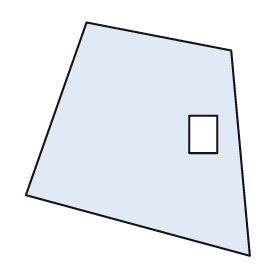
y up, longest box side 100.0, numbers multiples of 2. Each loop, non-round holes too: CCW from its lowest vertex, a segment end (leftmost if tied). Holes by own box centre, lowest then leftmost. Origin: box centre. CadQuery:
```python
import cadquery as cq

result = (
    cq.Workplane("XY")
    .moveTo(48.0, -50.0)
    .lineTo(40.0, 38.0)
    .lineTo(-22.0, 50.0)
    .lineTo(-48.0, -24.0)
    .close()
    .moveTo(22.0, -6.0)
    .lineTo(34.0, -6.0)
    .lineTo(34.0, 10.0)
    .lineTo(22.0, 10.0)
    .close()
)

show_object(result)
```